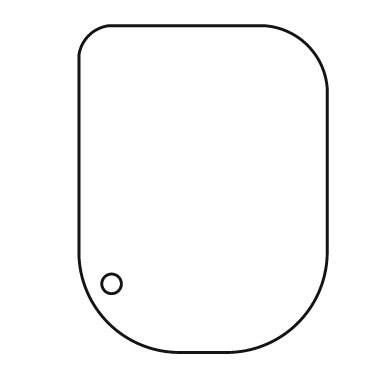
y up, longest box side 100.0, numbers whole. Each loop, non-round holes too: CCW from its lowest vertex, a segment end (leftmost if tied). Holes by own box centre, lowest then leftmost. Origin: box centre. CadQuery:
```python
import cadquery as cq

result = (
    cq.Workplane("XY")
    .moveTo(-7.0, -50.0)
    .lineTo(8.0, -50.0)
    .threePointArc((29.0, -41.0), (38.0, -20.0))
    .lineTo(38.0, 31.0)
    .threePointArc((32.0, 44.0), (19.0, 50.0))
    .lineTo(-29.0, 50.0)
    .threePointArc((-35.0, 47.0), (-38.0, 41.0))
    .lineTo(-38.0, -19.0)
    .threePointArc((-29.0, -41.0), (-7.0, -50.0))
    .close()
    .moveTo(-28.0, -29.0)
    .circle(3.0)
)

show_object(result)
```